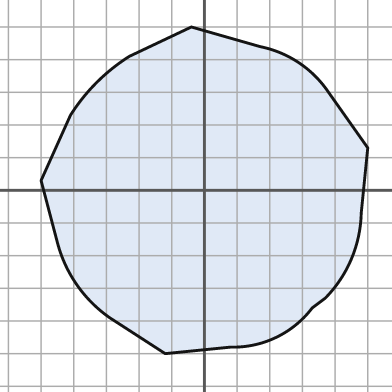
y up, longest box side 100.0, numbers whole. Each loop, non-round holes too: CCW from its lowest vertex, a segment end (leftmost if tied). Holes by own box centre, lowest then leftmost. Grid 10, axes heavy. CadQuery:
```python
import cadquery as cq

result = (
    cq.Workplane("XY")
    .moveTo(-12.0, -50.0)
    .lineTo(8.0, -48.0)
    .threePointArc((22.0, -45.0), (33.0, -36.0))
    .lineTo(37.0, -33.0)
    .threePointArc((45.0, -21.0), (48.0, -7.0))
    .lineTo(50.0, 13.0)
    .lineTo(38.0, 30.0)
    .threePointArc((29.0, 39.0), (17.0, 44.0))
    .lineTo(-4.0, 50.0)
    .lineTo(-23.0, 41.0)
    .threePointArc((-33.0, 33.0), (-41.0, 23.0))
    .lineTo(-50.0, 3.0)
    .lineTo(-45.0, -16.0)
    .threePointArc((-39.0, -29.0), (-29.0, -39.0))
    .close()
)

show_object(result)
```